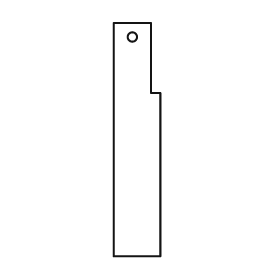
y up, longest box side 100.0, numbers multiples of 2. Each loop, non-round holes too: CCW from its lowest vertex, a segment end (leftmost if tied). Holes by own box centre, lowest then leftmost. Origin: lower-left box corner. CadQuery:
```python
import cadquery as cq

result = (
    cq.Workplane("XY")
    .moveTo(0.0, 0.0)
    .lineTo(20.0, 0.0)
    .lineTo(20.0, 70.0)
    .lineTo(16.0, 70.0)
    .lineTo(16.0, 100.0)
    .lineTo(0.0, 100.0)
    .close()
    .moveTo(8.0, 94.0)
    .circle(2.0)
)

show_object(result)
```